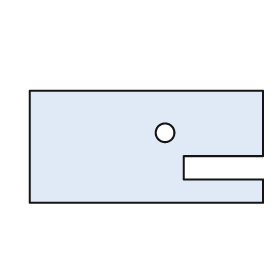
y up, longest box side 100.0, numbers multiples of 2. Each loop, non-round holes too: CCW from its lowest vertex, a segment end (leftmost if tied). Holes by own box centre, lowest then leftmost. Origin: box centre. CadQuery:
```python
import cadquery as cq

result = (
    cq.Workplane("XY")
    .moveTo(-50.0, -24.0)
    .lineTo(50.0, -24.0)
    .lineTo(50.0, -14.0)
    .lineTo(16.0, -14.0)
    .lineTo(16.0, -4.0)
    .lineTo(50.0, -4.0)
    .lineTo(50.0, 24.0)
    .lineTo(-50.0, 24.0)
    .close()
    .moveTo(8.0, 6.0)
    .circle(4.0)
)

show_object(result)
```